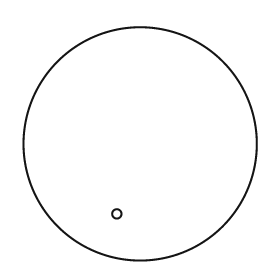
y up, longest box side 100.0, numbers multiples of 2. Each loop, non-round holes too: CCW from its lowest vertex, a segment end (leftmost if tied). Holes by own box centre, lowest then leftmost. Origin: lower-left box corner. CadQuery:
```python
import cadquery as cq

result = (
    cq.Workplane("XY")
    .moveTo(50.0, 50.0)
    .circle(50.0)
    .moveTo(40.0, 20.0)
    .circle(2.0)
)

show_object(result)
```